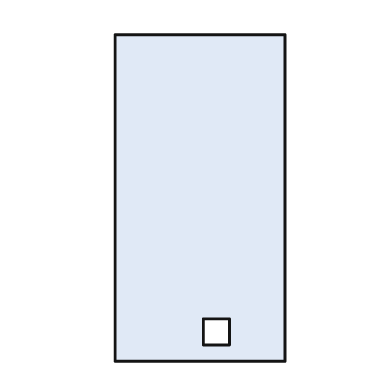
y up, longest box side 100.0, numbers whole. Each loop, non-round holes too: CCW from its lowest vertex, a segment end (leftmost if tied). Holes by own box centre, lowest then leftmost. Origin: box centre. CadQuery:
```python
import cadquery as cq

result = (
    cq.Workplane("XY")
    .moveTo(-26.0, -50.0)
    .lineTo(26.0, -50.0)
    .lineTo(26.0, 50.0)
    .lineTo(-26.0, 50.0)
    .close()
    .moveTo(1.0, -45.0)
    .lineTo(9.0, -45.0)
    .lineTo(9.0, -37.0)
    .lineTo(1.0, -37.0)
    .close()
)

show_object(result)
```